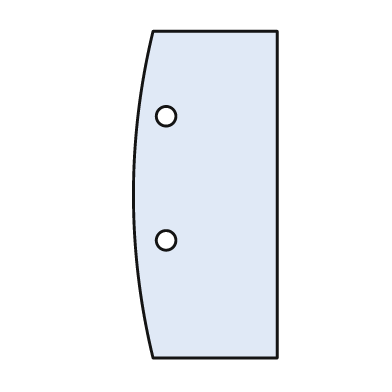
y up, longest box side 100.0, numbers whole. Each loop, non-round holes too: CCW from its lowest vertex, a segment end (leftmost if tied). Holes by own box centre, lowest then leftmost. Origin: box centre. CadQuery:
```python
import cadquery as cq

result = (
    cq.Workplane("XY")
    .moveTo(-16.0, -50.0)
    .lineTo(22.0, -50.0)
    .lineTo(22.0, 50.0)
    .lineTo(-16.0, 50.0)
    .threePointArc((-22.0, 0.0), (-16.0, -50.0))
    .close()
    .moveTo(-12.0, -14.0)
    .circle(3.0)
    .moveTo(-12.0, 24.0)
    .circle(3.0)
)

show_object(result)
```